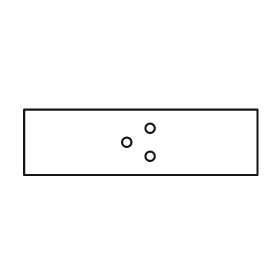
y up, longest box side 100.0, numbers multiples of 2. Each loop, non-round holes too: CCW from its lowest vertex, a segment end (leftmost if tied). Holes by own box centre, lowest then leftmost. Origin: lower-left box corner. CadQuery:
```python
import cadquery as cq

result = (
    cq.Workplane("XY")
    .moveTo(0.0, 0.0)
    .lineTo(100.0, 0.0)
    .lineTo(100.0, 28.0)
    .lineTo(0.0, 28.0)
    .close()
    .moveTo(54.0, 8.0)
    .circle(2.0)
    .moveTo(44.0, 14.0)
    .circle(2.0)
    .moveTo(54.0, 20.0)
    .circle(2.0)
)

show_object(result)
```